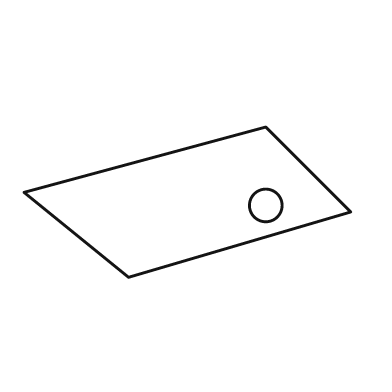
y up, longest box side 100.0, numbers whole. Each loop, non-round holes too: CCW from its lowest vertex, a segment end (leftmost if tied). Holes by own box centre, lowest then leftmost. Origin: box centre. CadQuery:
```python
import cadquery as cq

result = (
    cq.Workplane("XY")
    .moveTo(-18.0, -23.0)
    .lineTo(50.0, -3.0)
    .lineTo(24.0, 23.0)
    .lineTo(-50.0, 3.0)
    .close()
    .moveTo(24.0, -1.0)
    .circle(5.0)
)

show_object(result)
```